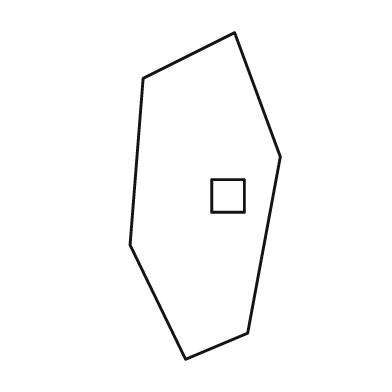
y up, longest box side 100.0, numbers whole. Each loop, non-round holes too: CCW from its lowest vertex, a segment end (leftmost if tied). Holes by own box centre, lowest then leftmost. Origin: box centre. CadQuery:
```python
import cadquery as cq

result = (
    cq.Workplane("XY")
    .moveTo(-6.0, -50.0)
    .lineTo(13.0, -42.0)
    .lineTo(23.0, 12.0)
    .lineTo(9.0, 50.0)
    .lineTo(-19.0, 36.0)
    .lineTo(-23.0, -15.0)
    .close()
    .moveTo(2.0, -5.0)
    .lineTo(12.0, -5.0)
    .lineTo(12.0, 5.0)
    .lineTo(2.0, 5.0)
    .close()
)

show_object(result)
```